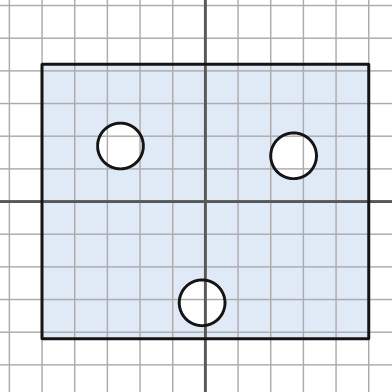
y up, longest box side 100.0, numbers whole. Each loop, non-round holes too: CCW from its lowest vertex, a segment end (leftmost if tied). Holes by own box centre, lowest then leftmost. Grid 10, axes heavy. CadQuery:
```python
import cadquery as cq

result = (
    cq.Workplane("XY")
    .moveTo(-50.0, -42.0)
    .lineTo(50.0, -42.0)
    .lineTo(50.0, 42.0)
    .lineTo(-50.0, 42.0)
    .close()
    .moveTo(-1.0, -31.0)
    .circle(7.0)
    .moveTo(27.0, 14.0)
    .circle(7.0)
    .moveTo(-26.0, 17.0)
    .circle(7.0)
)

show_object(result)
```